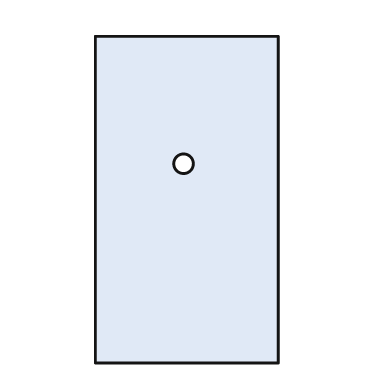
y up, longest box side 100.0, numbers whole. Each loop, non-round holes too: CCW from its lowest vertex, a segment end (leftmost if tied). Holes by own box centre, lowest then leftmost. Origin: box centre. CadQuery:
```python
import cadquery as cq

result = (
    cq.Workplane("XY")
    .moveTo(-28.0, -50.0)
    .lineTo(28.0, -50.0)
    .lineTo(28.0, 50.0)
    .lineTo(-28.0, 50.0)
    .close()
    .moveTo(-1.0, 11.0)
    .circle(3.0)
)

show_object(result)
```